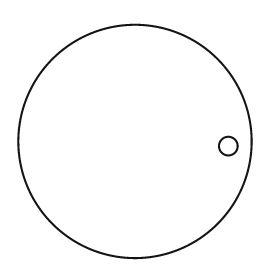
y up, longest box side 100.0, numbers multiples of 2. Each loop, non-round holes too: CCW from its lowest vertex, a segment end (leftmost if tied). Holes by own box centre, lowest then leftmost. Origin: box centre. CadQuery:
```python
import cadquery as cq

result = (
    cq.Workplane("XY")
    .moveTo(0.0, 0.0)
    .circle(50.0)
    .moveTo(40.0, -2.0)
    .circle(4.0)
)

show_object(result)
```